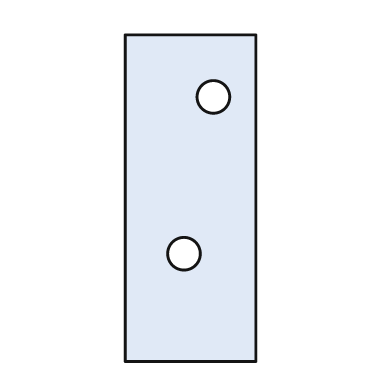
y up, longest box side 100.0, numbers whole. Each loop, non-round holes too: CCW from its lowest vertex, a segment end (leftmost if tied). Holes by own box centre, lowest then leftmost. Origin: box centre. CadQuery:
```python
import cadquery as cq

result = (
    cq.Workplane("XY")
    .moveTo(-20.0, -50.0)
    .lineTo(20.0, -50.0)
    .lineTo(20.0, 50.0)
    .lineTo(-20.0, 50.0)
    .close()
    .moveTo(-2.0, -17.0)
    .circle(5.0)
    .moveTo(7.0, 31.0)
    .circle(5.0)
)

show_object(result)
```